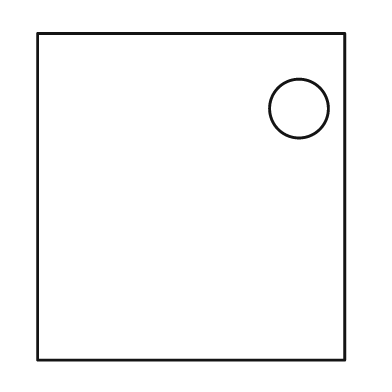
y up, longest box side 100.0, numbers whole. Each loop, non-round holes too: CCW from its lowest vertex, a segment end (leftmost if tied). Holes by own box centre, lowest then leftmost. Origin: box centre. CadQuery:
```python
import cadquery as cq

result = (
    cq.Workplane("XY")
    .moveTo(-47.0, -50.0)
    .lineTo(47.0, -50.0)
    .lineTo(47.0, 50.0)
    .lineTo(-47.0, 50.0)
    .close()
    .moveTo(33.0, 27.0)
    .circle(9.0)
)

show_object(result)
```